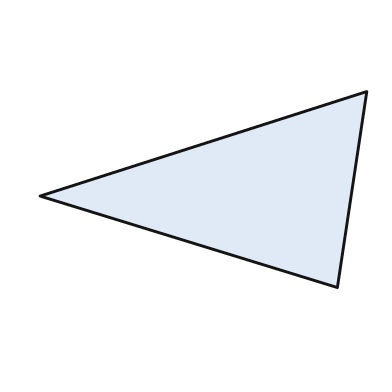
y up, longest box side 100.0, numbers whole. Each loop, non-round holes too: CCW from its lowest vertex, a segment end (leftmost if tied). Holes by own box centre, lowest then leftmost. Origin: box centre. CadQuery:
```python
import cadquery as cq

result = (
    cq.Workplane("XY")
    .moveTo(41.0, -30.0)
    .lineTo(50.0, 30.0)
    .lineTo(-50.0, -2.0)
    .close()
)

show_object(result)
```